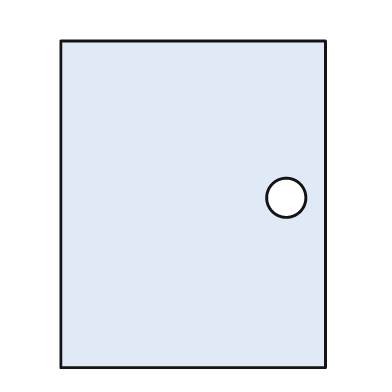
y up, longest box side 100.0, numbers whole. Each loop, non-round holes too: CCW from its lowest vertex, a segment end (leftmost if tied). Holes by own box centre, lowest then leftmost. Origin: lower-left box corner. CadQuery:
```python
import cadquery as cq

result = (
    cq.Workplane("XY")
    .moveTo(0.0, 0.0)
    .lineTo(81.0, 0.0)
    .lineTo(81.0, 100.0)
    .lineTo(0.0, 100.0)
    .close()
    .moveTo(69.0, 52.0)
    .circle(6.0)
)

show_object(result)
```